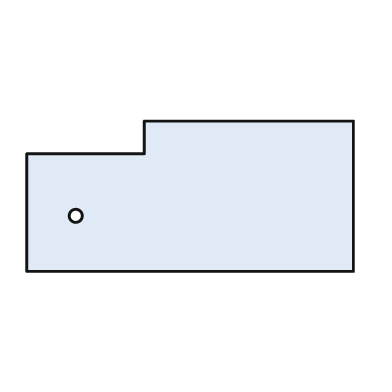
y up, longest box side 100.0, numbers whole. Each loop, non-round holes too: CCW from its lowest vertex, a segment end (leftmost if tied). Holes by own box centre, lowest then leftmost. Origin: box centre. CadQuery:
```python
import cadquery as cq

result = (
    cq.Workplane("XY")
    .moveTo(-50.0, -23.0)
    .lineTo(50.0, -23.0)
    .lineTo(50.0, 23.0)
    .lineTo(-14.0, 23.0)
    .lineTo(-14.0, 13.0)
    .lineTo(-50.0, 13.0)
    .close()
    .moveTo(-35.0, -6.0)
    .circle(2.0)
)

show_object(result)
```